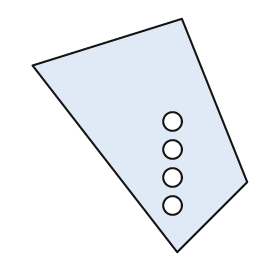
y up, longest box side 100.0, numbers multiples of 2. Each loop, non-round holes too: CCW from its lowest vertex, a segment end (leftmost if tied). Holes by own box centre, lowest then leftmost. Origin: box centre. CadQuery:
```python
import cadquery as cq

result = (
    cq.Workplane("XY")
    .moveTo(16.0, -50.0)
    .lineTo(46.0, -20.0)
    .lineTo(18.0, 50.0)
    .lineTo(-46.0, 30.0)
    .close()
    .moveTo(14.0, -30.0)
    .circle(4.0)
    .moveTo(14.0, -18.0)
    .circle(4.0)
    .moveTo(14.0, -6.0)
    .circle(4.0)
    .moveTo(14.0, 6.0)
    .circle(4.0)
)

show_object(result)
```